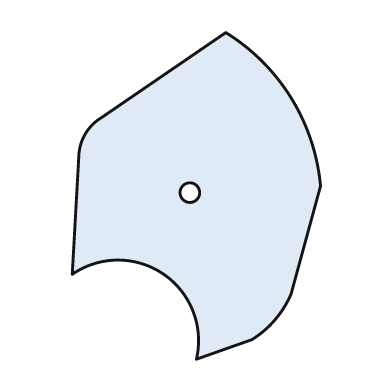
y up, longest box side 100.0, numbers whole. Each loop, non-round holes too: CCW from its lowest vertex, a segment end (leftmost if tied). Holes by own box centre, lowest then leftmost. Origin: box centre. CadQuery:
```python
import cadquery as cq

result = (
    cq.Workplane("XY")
    .moveTo(0.0, -50.0)
    .lineTo(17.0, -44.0)
    .threePointArc((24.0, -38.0), (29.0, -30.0))
    .lineTo(38.0, 3.0)
    .threePointArc((29.0, 30.0), (9.0, 50.0))
    .lineTo(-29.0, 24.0)
    .threePointArc((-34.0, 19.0), (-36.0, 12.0))
    .lineTo(-38.0, -24.0)
    .threePointArc((-10.0, -24.0), (0.0, -50.0))
    .close()
    .moveTo(-2.0, 1.0)
    .circle(3.0)
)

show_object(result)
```